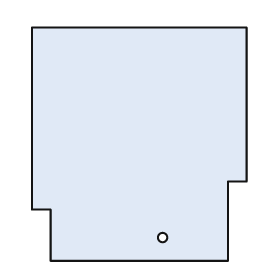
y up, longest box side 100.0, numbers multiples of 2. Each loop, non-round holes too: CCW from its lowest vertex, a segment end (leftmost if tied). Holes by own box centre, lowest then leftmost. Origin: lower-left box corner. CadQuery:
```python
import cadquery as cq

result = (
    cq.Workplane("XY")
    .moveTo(8.0, 0.0)
    .lineTo(84.0, 0.0)
    .lineTo(84.0, 34.0)
    .lineTo(92.0, 34.0)
    .lineTo(92.0, 100.0)
    .lineTo(0.0, 100.0)
    .lineTo(0.0, 22.0)
    .lineTo(8.0, 22.0)
    .close()
    .moveTo(56.0, 10.0)
    .circle(2.0)
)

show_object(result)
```